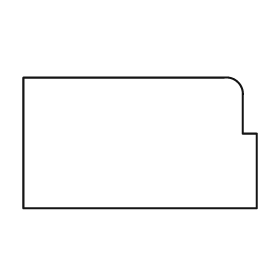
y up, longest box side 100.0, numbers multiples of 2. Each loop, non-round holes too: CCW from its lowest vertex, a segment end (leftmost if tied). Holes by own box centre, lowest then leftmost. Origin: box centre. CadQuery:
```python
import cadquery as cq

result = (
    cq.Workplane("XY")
    .moveTo(-50.0, -28.0)
    .lineTo(50.0, -28.0)
    .lineTo(50.0, 4.0)
    .lineTo(44.0, 4.0)
    .lineTo(44.0, 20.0)
    .threePointArc((42.0, 26.0), (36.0, 28.0))
    .lineTo(-50.0, 28.0)
    .close()
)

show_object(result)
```